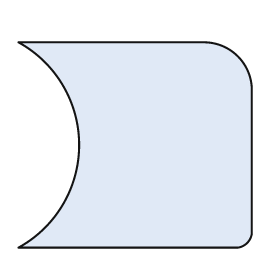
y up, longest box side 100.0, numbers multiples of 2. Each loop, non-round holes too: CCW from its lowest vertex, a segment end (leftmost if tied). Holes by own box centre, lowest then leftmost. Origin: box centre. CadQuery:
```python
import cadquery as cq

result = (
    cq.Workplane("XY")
    .moveTo(-50.0, -44.0)
    .lineTo(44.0, -44.0)
    .threePointArc((48.0, -42.0), (50.0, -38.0))
    .lineTo(50.0, 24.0)
    .threePointArc((44.0, 38.0), (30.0, 44.0))
    .lineTo(-50.0, 44.0)
    .threePointArc((-24.0, 0.0), (-50.0, -44.0))
    .close()
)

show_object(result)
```